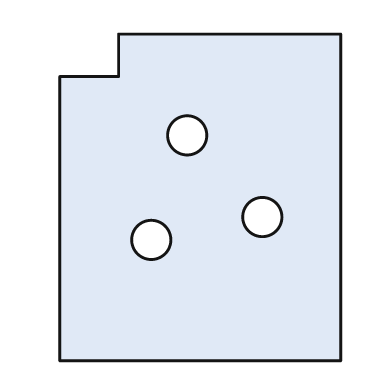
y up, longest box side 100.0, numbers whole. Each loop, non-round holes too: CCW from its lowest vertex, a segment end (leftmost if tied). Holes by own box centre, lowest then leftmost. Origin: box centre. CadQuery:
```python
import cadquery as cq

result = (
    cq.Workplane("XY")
    .moveTo(-43.0, -50.0)
    .lineTo(43.0, -50.0)
    .lineTo(43.0, 50.0)
    .lineTo(-25.0, 50.0)
    .lineTo(-25.0, 37.0)
    .lineTo(-43.0, 37.0)
    .close()
    .moveTo(-15.0, -13.0)
    .circle(6.0)
    .moveTo(19.0, -6.0)
    .circle(6.0)
    .moveTo(-4.0, 19.0)
    .circle(6.0)
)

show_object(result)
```